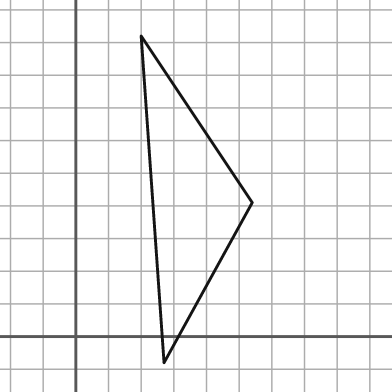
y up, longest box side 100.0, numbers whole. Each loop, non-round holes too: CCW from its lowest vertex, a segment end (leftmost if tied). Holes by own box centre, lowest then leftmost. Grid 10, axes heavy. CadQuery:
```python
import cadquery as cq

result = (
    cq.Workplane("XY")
    .moveTo(27.0, -8.0)
    .lineTo(54.0, 41.0)
    .lineTo(20.0, 92.0)
    .close()
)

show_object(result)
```